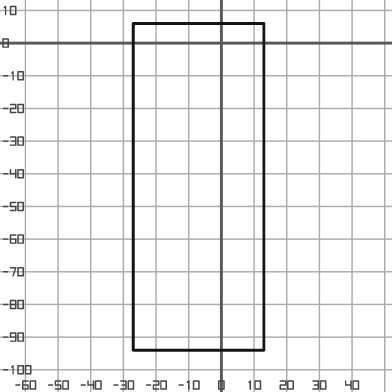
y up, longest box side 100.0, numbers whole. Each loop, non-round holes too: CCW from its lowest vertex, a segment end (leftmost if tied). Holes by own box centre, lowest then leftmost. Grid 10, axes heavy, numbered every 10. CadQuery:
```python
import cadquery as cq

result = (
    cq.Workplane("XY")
    .moveTo(-27.0, -94.0)
    .lineTo(13.0, -94.0)
    .lineTo(13.0, 6.0)
    .lineTo(-27.0, 6.0)
    .close()
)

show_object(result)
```